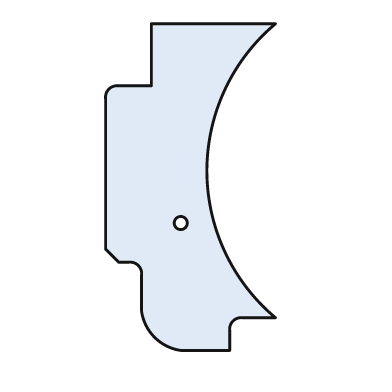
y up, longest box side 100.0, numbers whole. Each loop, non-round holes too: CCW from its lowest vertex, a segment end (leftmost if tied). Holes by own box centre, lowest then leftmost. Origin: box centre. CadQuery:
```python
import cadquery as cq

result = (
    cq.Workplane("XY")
    .moveTo(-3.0, -50.0)
    .lineTo(12.0, -50.0)
    .lineTo(12.0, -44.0)
    .threePointArc((13.0, -41.0), (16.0, -40.0))
    .lineTo(26.0, -40.0)
    .threePointArc((5.0, 5.0), (26.0, 50.0))
    .lineTo(-12.0, 50.0)
    .lineTo(-12.0, 31.0)
    .lineTo(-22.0, 31.0)
    .threePointArc((-25.0, 30.0), (-26.0, 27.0))
    .lineTo(-26.0, -19.0)
    .lineTo(-22.0, -23.0)
    .lineTo(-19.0, -23.0)
    .threePointArc((-16.0, -24.0), (-15.0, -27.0))
    .lineTo(-15.0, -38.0)
    .threePointArc((-11.0, -46.0), (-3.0, -50.0))
    .close()
    .moveTo(-3.0, -11.0)
    .circle(2.0)
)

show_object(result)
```